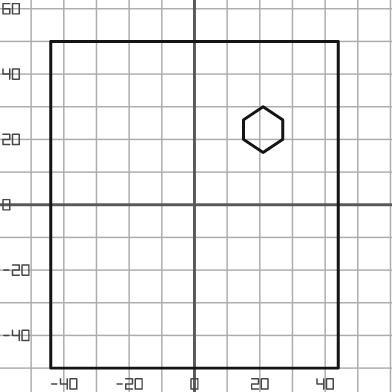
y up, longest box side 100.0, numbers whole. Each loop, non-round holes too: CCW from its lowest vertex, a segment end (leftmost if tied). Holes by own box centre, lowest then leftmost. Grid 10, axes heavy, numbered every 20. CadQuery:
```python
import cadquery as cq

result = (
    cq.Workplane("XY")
    .moveTo(-44.0, -50.0)
    .lineTo(44.0, -50.0)
    .lineTo(44.0, 50.0)
    .lineTo(-44.0, 50.0)
    .close()
    .moveTo(21.0, 16.0)
    .lineTo(27.0, 20.0)
    .lineTo(27.0, 26.0)
    .lineTo(21.0, 30.0)
    .lineTo(15.0, 26.0)
    .lineTo(15.0, 20.0)
    .close()
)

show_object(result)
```